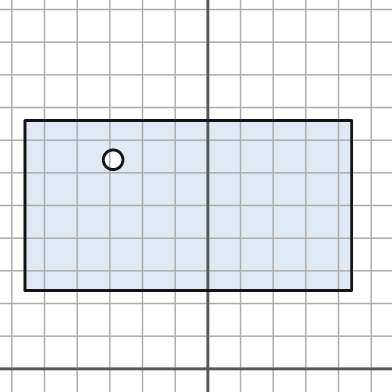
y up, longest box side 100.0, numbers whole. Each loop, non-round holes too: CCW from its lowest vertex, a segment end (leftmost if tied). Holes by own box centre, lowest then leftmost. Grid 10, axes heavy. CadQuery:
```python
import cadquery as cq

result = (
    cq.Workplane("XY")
    .moveTo(-56.0, 24.0)
    .lineTo(44.0, 24.0)
    .lineTo(44.0, 76.0)
    .lineTo(-56.0, 76.0)
    .close()
    .moveTo(-29.0, 64.0)
    .circle(3.0)
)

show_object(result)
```